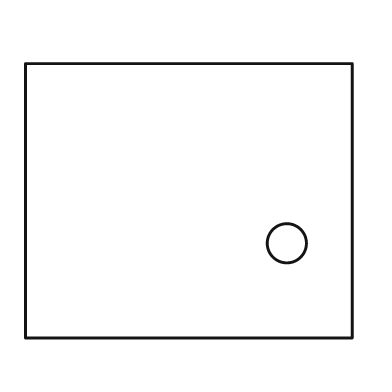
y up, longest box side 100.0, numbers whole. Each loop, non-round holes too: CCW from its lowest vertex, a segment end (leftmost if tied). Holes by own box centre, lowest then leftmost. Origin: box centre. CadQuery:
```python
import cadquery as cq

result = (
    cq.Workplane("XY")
    .moveTo(-50.0, -42.0)
    .lineTo(50.0, -42.0)
    .lineTo(50.0, 42.0)
    .lineTo(-50.0, 42.0)
    .close()
    .moveTo(30.0, -13.0)
    .circle(6.0)
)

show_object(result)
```